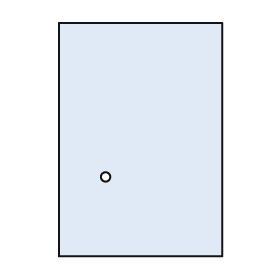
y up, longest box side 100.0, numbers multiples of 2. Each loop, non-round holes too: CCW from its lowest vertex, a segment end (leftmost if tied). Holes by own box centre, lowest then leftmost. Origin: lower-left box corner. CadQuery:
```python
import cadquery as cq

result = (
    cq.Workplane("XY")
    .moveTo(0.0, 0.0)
    .lineTo(70.0, 0.0)
    .lineTo(70.0, 100.0)
    .lineTo(0.0, 100.0)
    .close()
    .moveTo(20.0, 34.0)
    .circle(2.0)
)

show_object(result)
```